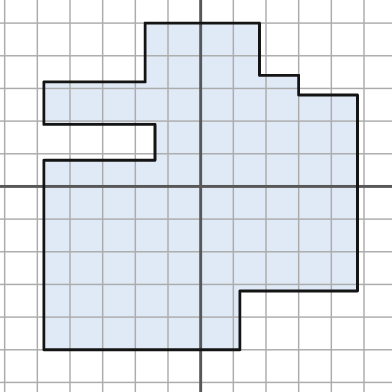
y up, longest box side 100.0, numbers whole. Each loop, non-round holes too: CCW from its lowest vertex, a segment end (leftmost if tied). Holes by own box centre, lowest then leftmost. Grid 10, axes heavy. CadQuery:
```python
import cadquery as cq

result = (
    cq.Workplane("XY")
    .moveTo(-48.0, -50.0)
    .lineTo(12.0, -50.0)
    .lineTo(12.0, -32.0)
    .lineTo(48.0, -32.0)
    .lineTo(48.0, 28.0)
    .lineTo(30.0, 28.0)
    .lineTo(30.0, 34.0)
    .lineTo(18.0, 34.0)
    .lineTo(18.0, 50.0)
    .lineTo(-17.0, 50.0)
    .lineTo(-17.0, 32.0)
    .lineTo(-48.0, 32.0)
    .lineTo(-48.0, 19.0)
    .lineTo(-14.0, 19.0)
    .lineTo(-14.0, 8.0)
    .lineTo(-48.0, 8.0)
    .close()
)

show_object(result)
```